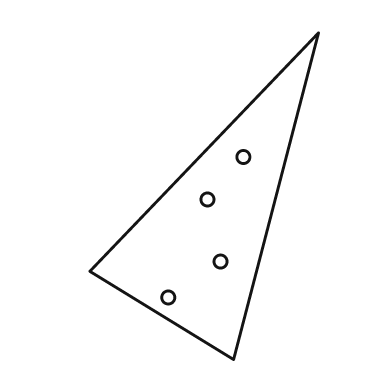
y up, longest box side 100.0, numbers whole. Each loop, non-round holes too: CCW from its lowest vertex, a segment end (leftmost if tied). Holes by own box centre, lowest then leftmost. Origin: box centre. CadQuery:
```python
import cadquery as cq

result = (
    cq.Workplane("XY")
    .moveTo(9.0, -50.0)
    .lineTo(35.0, 50.0)
    .lineTo(-35.0, -23.0)
    .close()
    .moveTo(-11.0, -31.0)
    .circle(2.0)
    .moveTo(5.0, -20.0)
    .circle(2.0)
    .moveTo(1.0, -1.0)
    .circle(2.0)
    .moveTo(12.0, 12.0)
    .circle(2.0)
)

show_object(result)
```